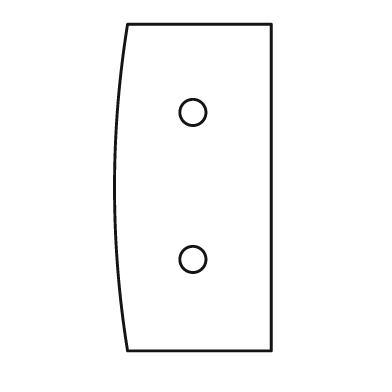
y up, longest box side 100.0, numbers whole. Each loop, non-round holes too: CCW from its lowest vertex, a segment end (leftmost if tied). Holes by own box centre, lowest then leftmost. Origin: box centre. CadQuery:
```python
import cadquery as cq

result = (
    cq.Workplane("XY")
    .moveTo(-20.0, -50.0)
    .lineTo(24.0, -50.0)
    .lineTo(24.0, 50.0)
    .lineTo(-20.0, 50.0)
    .threePointArc((-24.0, 0.0), (-20.0, -50.0))
    .close()
    .moveTo(0.0, -22.0)
    .circle(4.0)
    .moveTo(0.0, 23.0)
    .circle(4.0)
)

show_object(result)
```